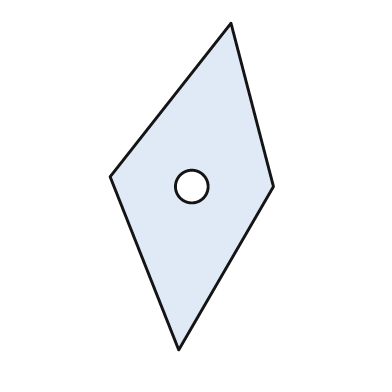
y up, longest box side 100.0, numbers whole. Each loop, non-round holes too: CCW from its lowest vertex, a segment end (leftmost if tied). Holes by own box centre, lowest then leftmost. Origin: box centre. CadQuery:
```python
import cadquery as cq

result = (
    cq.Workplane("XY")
    .moveTo(-4.0, -50.0)
    .lineTo(25.0, 0.0)
    .lineTo(12.0, 50.0)
    .lineTo(-25.0, 3.0)
    .close()
    .moveTo(0.0, 0.0)
    .circle(5.0)
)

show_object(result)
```